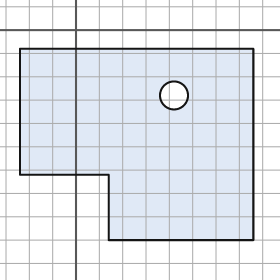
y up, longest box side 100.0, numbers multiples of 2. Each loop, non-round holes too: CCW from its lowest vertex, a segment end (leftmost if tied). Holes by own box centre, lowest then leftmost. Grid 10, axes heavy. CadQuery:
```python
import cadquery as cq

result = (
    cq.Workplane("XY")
    .moveTo(14.0, -90.0)
    .lineTo(76.0, -90.0)
    .lineTo(76.0, -8.0)
    .lineTo(-24.0, -8.0)
    .lineTo(-24.0, -62.0)
    .lineTo(14.0, -62.0)
    .close()
    .moveTo(42.0, -28.0)
    .circle(6.0)
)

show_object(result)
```